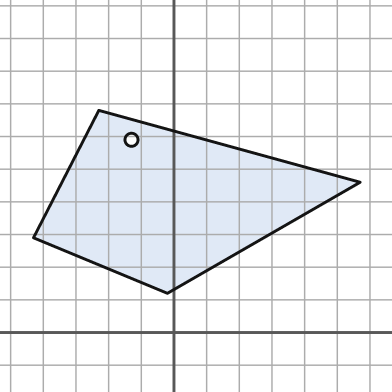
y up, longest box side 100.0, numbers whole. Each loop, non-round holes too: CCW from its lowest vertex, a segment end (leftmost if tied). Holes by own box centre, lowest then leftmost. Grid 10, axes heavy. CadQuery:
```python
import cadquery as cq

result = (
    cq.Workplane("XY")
    .moveTo(-2.0, 12.0)
    .lineTo(57.0, 46.0)
    .lineTo(-23.0, 68.0)
    .lineTo(-43.0, 29.0)
    .close()
    .moveTo(-13.0, 59.0)
    .circle(2.0)
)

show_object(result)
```